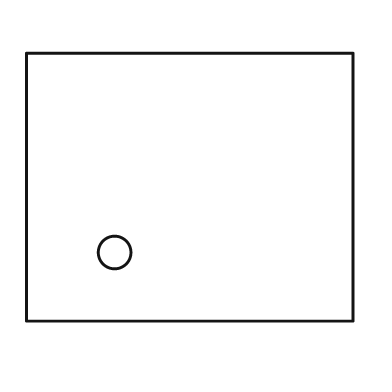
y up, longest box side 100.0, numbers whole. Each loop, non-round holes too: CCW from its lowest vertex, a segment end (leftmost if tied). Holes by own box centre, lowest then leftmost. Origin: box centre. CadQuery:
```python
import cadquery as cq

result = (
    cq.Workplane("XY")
    .moveTo(-50.0, -41.0)
    .lineTo(50.0, -41.0)
    .lineTo(50.0, 41.0)
    .lineTo(-50.0, 41.0)
    .close()
    .moveTo(-23.0, -20.0)
    .circle(5.0)
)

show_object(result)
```